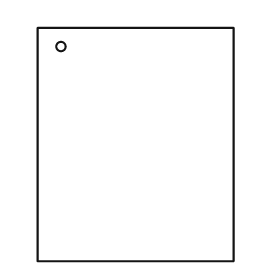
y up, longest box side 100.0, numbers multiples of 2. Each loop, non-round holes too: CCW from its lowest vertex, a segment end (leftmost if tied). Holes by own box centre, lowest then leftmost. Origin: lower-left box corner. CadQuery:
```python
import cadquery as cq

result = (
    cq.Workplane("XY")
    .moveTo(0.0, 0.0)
    .lineTo(84.0, 0.0)
    .lineTo(84.0, 100.0)
    .lineTo(0.0, 100.0)
    .close()
    .moveTo(10.0, 92.0)
    .circle(2.0)
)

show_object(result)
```